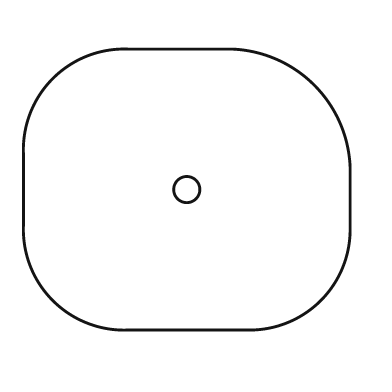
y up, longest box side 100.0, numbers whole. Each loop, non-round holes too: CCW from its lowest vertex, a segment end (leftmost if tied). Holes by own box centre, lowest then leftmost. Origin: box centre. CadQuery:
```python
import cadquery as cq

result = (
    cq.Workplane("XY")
    .moveTo(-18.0, -43.0)
    .lineTo(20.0, -43.0)
    .threePointArc((41.0, -34.0), (50.0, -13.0))
    .lineTo(50.0, 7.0)
    .threePointArc((39.0, 32.0), (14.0, 43.0))
    .lineTo(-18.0, 43.0)
    .threePointArc((-41.0, 34.0), (-50.0, 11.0))
    .lineTo(-50.0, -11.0)
    .threePointArc((-41.0, -34.0), (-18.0, -43.0))
    .close()
    .moveTo(0.0, 0.0)
    .circle(4.0)
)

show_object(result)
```